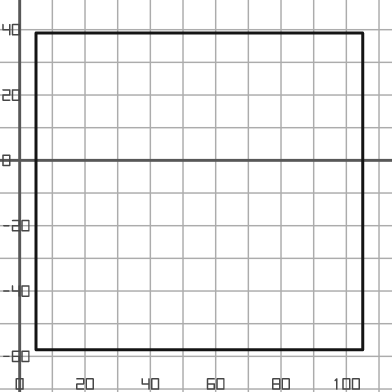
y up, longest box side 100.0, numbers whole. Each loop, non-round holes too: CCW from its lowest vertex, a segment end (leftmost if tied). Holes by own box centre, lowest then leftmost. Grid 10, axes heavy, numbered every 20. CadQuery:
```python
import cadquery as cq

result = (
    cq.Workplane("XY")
    .moveTo(5.0, -58.0)
    .lineTo(105.0, -58.0)
    .lineTo(105.0, 39.0)
    .lineTo(5.0, 39.0)
    .close()
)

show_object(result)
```